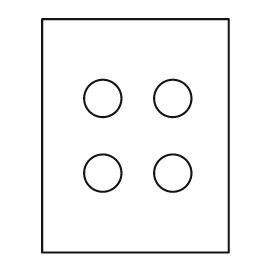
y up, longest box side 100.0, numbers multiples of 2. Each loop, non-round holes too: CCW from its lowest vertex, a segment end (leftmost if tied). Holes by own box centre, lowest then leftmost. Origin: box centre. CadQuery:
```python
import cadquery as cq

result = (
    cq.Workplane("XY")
    .moveTo(-40.0, -50.0)
    .lineTo(40.0, -50.0)
    .lineTo(40.0, 50.0)
    .lineTo(-40.0, 50.0)
    .close()
    .moveTo(-14.0, -16.0)
    .circle(8.0)
    .moveTo(16.0, -16.0)
    .circle(8.0)
    .moveTo(-14.0, 16.0)
    .circle(8.0)
    .moveTo(16.0, 16.0)
    .circle(8.0)
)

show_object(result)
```